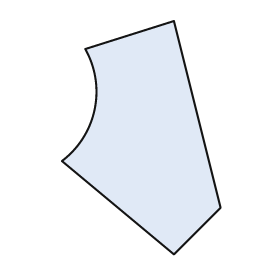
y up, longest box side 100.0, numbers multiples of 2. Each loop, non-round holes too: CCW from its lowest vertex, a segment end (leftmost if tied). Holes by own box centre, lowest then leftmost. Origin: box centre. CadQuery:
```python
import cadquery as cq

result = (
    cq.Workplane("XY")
    .moveTo(14.0, -50.0)
    .lineTo(34.0, -30.0)
    .lineTo(14.0, 50.0)
    .lineTo(-24.0, 38.0)
    .threePointArc((-20.0, 12.0), (-34.0, -10.0))
    .close()
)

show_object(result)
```